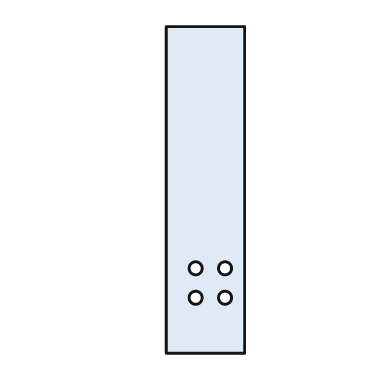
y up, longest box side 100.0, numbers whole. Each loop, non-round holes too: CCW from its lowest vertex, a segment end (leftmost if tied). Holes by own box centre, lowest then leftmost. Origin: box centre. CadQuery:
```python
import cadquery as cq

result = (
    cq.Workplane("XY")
    .moveTo(-12.0, -50.0)
    .lineTo(12.0, -50.0)
    .lineTo(12.0, 50.0)
    .lineTo(-12.0, 50.0)
    .close()
    .moveTo(-3.0, -33.0)
    .circle(2.0)
    .moveTo(6.0, -33.0)
    .circle(2.0)
    .moveTo(-3.0, -24.0)
    .circle(2.0)
    .moveTo(6.0, -24.0)
    .circle(2.0)
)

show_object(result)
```